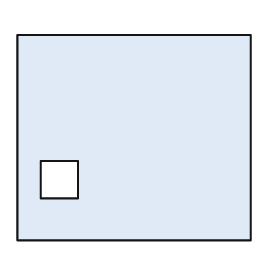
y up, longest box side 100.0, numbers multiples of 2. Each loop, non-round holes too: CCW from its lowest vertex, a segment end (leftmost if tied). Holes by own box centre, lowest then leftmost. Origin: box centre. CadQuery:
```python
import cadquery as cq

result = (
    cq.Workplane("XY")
    .moveTo(-50.0, -44.0)
    .lineTo(50.0, -44.0)
    .lineTo(50.0, 44.0)
    .lineTo(-50.0, 44.0)
    .close()
    .moveTo(-40.0, -26.0)
    .lineTo(-24.0, -26.0)
    .lineTo(-24.0, -10.0)
    .lineTo(-40.0, -10.0)
    .close()
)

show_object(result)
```